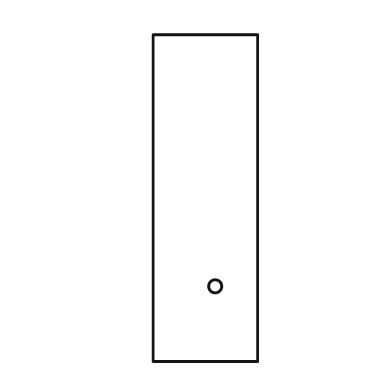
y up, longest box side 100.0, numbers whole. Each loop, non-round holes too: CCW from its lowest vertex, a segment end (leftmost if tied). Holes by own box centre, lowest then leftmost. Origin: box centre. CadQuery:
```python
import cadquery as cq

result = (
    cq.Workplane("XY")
    .moveTo(-16.0, -50.0)
    .lineTo(16.0, -50.0)
    .lineTo(16.0, 50.0)
    .lineTo(-16.0, 50.0)
    .close()
    .moveTo(3.0, -27.0)
    .circle(2.0)
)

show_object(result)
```